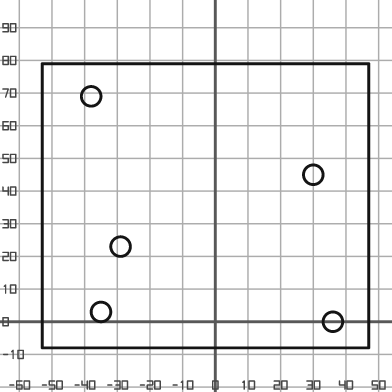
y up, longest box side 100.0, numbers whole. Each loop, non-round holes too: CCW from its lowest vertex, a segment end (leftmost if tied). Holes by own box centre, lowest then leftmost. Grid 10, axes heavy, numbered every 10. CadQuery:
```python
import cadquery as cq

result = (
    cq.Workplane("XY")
    .moveTo(-53.0, -8.0)
    .lineTo(47.0, -8.0)
    .lineTo(47.0, 79.0)
    .lineTo(-53.0, 79.0)
    .close()
    .moveTo(36.0, 0.0)
    .circle(3.0)
    .moveTo(-35.0, 3.0)
    .circle(3.0)
    .moveTo(-29.0, 23.0)
    .circle(3.0)
    .moveTo(30.0, 45.0)
    .circle(3.0)
    .moveTo(-38.0, 69.0)
    .circle(3.0)
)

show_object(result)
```